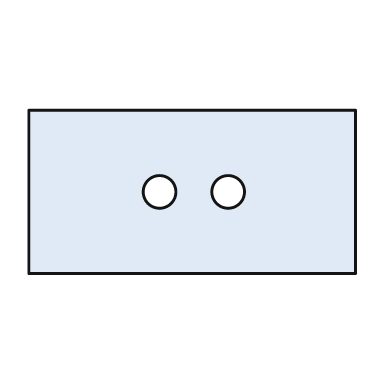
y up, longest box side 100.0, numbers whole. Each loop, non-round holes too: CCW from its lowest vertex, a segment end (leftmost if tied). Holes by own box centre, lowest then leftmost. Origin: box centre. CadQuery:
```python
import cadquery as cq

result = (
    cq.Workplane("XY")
    .moveTo(-50.0, -25.0)
    .lineTo(50.0, -25.0)
    .lineTo(50.0, 25.0)
    .lineTo(-50.0, 25.0)
    .close()
    .moveTo(-10.0, 0.0)
    .circle(5.0)
    .moveTo(11.0, 0.0)
    .circle(5.0)
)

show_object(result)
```